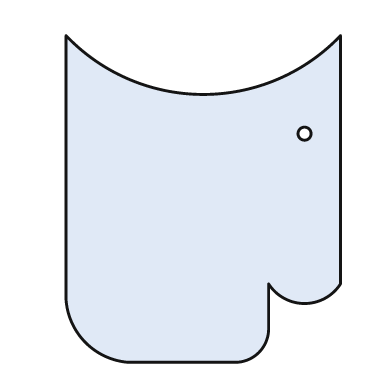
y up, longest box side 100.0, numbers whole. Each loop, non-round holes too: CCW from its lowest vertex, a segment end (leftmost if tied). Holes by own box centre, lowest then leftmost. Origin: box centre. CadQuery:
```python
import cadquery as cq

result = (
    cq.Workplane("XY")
    .moveTo(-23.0, -50.0)
    .lineTo(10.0, -50.0)
    .threePointArc((17.0, -47.0), (20.0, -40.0))
    .lineTo(20.0, -26.0)
    .threePointArc((31.0, -32.0), (42.0, -26.0))
    .lineTo(42.0, 50.0)
    .threePointArc((0.0, 32.0), (-42.0, 50.0))
    .lineTo(-42.0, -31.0)
    .threePointArc((-36.0, -44.0), (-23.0, -50.0))
    .close()
    .moveTo(31.0, 20.0)
    .circle(2.0)
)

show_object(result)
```